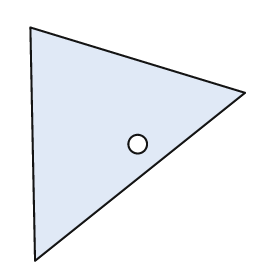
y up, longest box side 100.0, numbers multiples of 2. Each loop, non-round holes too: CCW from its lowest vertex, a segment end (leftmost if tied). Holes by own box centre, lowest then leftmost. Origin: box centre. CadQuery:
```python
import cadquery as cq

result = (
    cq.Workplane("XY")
    .moveTo(-44.0, -50.0)
    .lineTo(46.0, 22.0)
    .lineTo(-46.0, 50.0)
    .close()
    .moveTo(0.0, 0.0)
    .circle(4.0)
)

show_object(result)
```